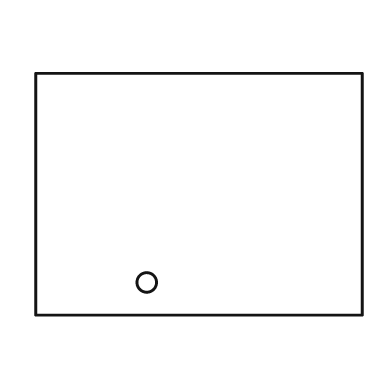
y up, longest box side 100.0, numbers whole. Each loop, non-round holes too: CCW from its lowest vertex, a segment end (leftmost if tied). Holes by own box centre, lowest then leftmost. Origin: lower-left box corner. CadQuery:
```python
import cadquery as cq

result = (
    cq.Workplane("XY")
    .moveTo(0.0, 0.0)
    .lineTo(100.0, 0.0)
    .lineTo(100.0, 74.0)
    .lineTo(0.0, 74.0)
    .close()
    .moveTo(34.0, 10.0)
    .circle(3.0)
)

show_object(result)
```